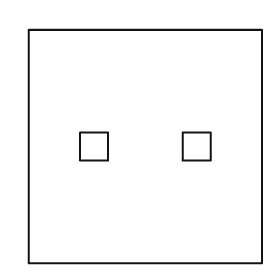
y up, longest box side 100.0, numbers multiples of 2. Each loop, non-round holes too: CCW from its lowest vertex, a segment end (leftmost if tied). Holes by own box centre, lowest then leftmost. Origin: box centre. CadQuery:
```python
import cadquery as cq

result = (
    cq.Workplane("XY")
    .moveTo(-50.0, -50.0)
    .lineTo(50.0, -50.0)
    .lineTo(50.0, 50.0)
    .lineTo(-50.0, 50.0)
    .close()
    .moveTo(-28.0, -6.0)
    .lineTo(-16.0, -6.0)
    .lineTo(-16.0, 6.0)
    .lineTo(-28.0, 6.0)
    .close()
    .moveTo(16.0, -6.0)
    .lineTo(28.0, -6.0)
    .lineTo(28.0, 6.0)
    .lineTo(16.0, 6.0)
    .close()
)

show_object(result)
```